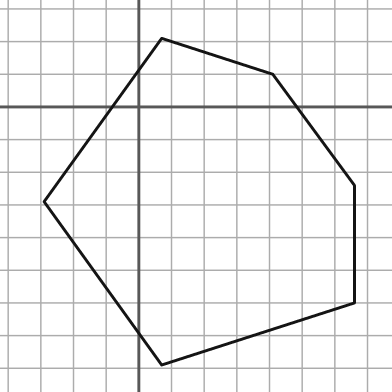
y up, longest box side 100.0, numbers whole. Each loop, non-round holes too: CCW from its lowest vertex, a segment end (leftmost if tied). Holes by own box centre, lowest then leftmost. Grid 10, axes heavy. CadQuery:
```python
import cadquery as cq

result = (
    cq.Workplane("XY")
    .moveTo(7.0, -79.0)
    .lineTo(66.0, -60.0)
    .lineTo(66.0, -24.0)
    .lineTo(41.0, 10.0)
    .lineTo(7.0, 21.0)
    .lineTo(-29.0, -29.0)
    .close()
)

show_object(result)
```